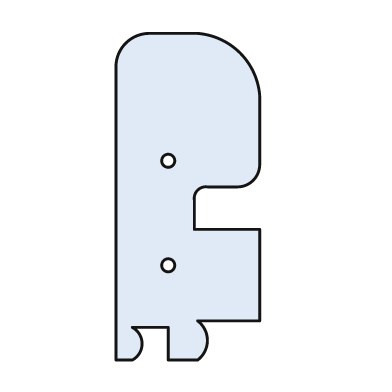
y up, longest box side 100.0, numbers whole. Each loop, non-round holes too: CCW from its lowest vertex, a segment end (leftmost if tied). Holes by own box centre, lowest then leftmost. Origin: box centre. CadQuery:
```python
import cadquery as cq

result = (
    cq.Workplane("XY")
    .moveTo(-22.0, -50.0)
    .lineTo(-17.0, -50.0)
    .threePointArc((-14.0, -45.0), (-17.0, -40.0))
    .lineTo(-6.0, -40.0)
    .lineTo(-6.0, -50.0)
    .lineTo(3.0, -50.0)
    .threePointArc((6.0, -44.0), (3.0, -38.0))
    .lineTo(22.0, -38.0)
    .lineTo(22.0, -10.0)
    .lineTo(2.0, -10.0)
    .lineTo(2.0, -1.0)
    .threePointArc((3.0, 2.0), (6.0, 3.0))
    .lineTo(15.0, 3.0)
    .threePointArc((20.0, 5.0), (22.0, 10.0))
    .lineTo(22.0, 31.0)
    .threePointArc((16.0, 44.0), (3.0, 50.0))
    .lineTo(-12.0, 50.0)
    .threePointArc((-19.0, 47.0), (-22.0, 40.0))
    .close()
    .moveTo(-6.0, -21.0)
    .circle(2.0)
    .moveTo(-6.0, 11.0)
    .circle(2.0)
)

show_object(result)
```